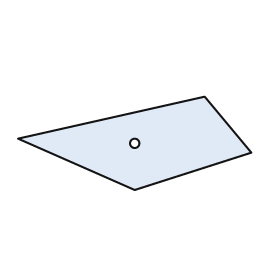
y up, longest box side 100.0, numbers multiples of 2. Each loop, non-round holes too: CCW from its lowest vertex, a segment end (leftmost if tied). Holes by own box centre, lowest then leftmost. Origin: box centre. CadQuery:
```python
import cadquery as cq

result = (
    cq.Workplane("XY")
    .moveTo(0.0, -20.0)
    .lineTo(50.0, -4.0)
    .lineTo(30.0, 20.0)
    .lineTo(-50.0, 2.0)
    .close()
    .moveTo(0.0, 0.0)
    .circle(2.0)
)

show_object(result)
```